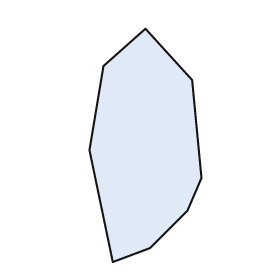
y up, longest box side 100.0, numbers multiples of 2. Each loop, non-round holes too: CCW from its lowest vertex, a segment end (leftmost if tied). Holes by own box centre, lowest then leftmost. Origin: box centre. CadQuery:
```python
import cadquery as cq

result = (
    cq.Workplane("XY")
    .moveTo(-14.0, -50.0)
    .lineTo(2.0, -44.0)
    .lineTo(18.0, -28.0)
    .lineTo(24.0, -14.0)
    .lineTo(20.0, 28.0)
    .lineTo(0.0, 50.0)
    .lineTo(-18.0, 34.0)
    .lineTo(-24.0, -2.0)
    .close()
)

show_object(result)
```